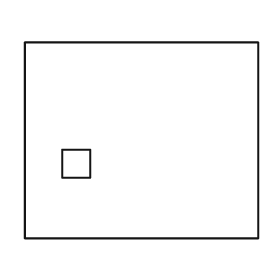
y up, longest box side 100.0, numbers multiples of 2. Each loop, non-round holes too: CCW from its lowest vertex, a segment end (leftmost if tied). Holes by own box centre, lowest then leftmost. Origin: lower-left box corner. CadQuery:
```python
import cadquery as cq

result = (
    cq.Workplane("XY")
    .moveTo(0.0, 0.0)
    .lineTo(100.0, 0.0)
    .lineTo(100.0, 84.0)
    .lineTo(0.0, 84.0)
    .close()
    .moveTo(16.0, 26.0)
    .lineTo(28.0, 26.0)
    .lineTo(28.0, 38.0)
    .lineTo(16.0, 38.0)
    .close()
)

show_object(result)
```